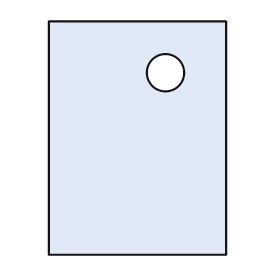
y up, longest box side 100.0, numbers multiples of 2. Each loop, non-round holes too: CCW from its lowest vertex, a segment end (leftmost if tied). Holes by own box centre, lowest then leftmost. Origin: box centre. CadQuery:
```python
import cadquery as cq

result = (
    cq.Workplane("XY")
    .moveTo(-38.0, -50.0)
    .lineTo(38.0, -50.0)
    .lineTo(38.0, 50.0)
    .lineTo(-38.0, 50.0)
    .close()
    .moveTo(12.0, 28.0)
    .circle(8.0)
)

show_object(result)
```